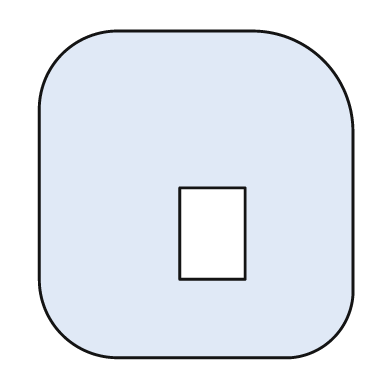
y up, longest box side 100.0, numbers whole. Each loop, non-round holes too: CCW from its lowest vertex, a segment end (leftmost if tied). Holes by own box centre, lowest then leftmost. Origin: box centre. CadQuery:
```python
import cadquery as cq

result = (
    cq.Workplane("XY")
    .moveTo(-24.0, -50.0)
    .lineTo(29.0, -50.0)
    .threePointArc((42.0, -44.0), (48.0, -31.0))
    .lineTo(48.0, 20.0)
    .threePointArc((39.0, 41.0), (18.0, 50.0))
    .lineTo(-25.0, 50.0)
    .threePointArc((-41.0, 43.0), (-48.0, 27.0))
    .lineTo(-48.0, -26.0)
    .threePointArc((-41.0, -43.0), (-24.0, -50.0))
    .close()
    .moveTo(-5.0, -26.0)
    .lineTo(15.0, -26.0)
    .lineTo(15.0, 2.0)
    .lineTo(-5.0, 2.0)
    .close()
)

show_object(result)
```